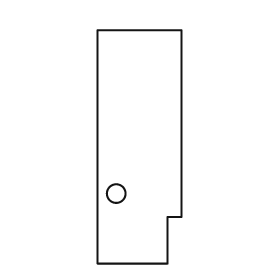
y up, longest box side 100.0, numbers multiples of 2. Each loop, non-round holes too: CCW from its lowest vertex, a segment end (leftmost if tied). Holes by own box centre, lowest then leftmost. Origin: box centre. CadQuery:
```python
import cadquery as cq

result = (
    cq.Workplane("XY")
    .moveTo(-18.0, -50.0)
    .lineTo(12.0, -50.0)
    .lineTo(12.0, -30.0)
    .lineTo(18.0, -30.0)
    .lineTo(18.0, 50.0)
    .lineTo(-18.0, 50.0)
    .close()
    .moveTo(-10.0, -20.0)
    .circle(4.0)
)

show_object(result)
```